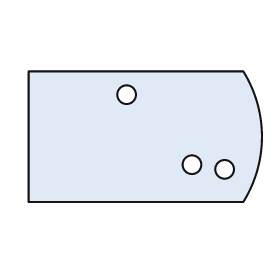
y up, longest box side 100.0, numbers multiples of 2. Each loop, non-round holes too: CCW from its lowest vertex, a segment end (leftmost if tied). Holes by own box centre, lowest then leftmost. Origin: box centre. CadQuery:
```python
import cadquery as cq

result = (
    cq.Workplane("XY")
    .moveTo(-50.0, -28.0)
    .lineTo(42.0, -28.0)
    .threePointArc((50.0, 0.0), (42.0, 28.0))
    .lineTo(-50.0, 28.0)
    .close()
    .moveTo(34.0, -14.0)
    .circle(4.0)
    .moveTo(20.0, -12.0)
    .circle(4.0)
    .moveTo(-8.0, 18.0)
    .circle(4.0)
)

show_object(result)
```